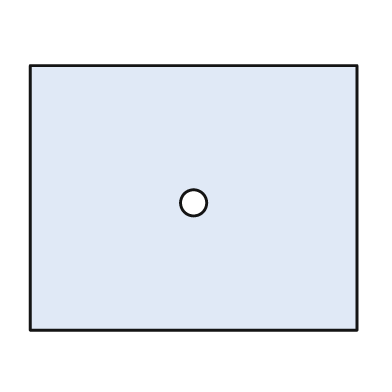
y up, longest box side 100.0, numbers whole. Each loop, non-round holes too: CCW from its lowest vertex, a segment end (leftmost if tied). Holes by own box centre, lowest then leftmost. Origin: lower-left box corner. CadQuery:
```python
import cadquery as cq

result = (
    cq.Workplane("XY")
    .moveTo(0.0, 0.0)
    .lineTo(100.0, 0.0)
    .lineTo(100.0, 81.0)
    .lineTo(0.0, 81.0)
    .close()
    .moveTo(50.0, 39.0)
    .circle(4.0)
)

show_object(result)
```